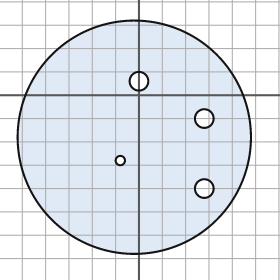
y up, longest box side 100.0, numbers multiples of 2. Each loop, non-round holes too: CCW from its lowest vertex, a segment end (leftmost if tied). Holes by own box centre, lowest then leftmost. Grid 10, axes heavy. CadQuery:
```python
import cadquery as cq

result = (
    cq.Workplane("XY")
    .moveTo(-2.0, -18.0)
    .circle(50.0)
    .moveTo(28.0, -40.0)
    .circle(4.0)
    .moveTo(-8.0, -28.0)
    .circle(2.0)
    .moveTo(28.0, -10.0)
    .circle(4.0)
    .moveTo(0.0, 6.0)
    .circle(4.0)
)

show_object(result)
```